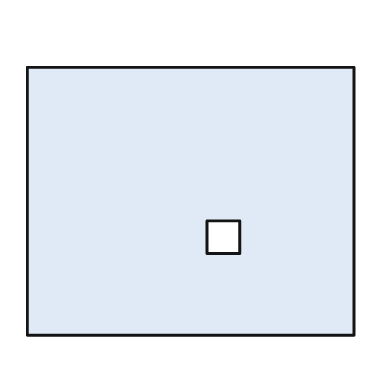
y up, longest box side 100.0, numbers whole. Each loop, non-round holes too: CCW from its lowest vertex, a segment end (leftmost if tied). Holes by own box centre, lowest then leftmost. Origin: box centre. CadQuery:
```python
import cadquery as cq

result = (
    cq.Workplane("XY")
    .moveTo(-50.0, -41.0)
    .lineTo(50.0, -41.0)
    .lineTo(50.0, 41.0)
    .lineTo(-50.0, 41.0)
    .close()
    .moveTo(5.0, -16.0)
    .lineTo(15.0, -16.0)
    .lineTo(15.0, -6.0)
    .lineTo(5.0, -6.0)
    .close()
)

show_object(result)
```